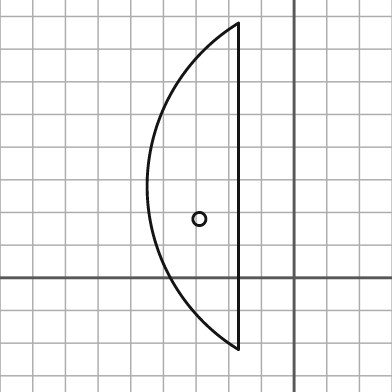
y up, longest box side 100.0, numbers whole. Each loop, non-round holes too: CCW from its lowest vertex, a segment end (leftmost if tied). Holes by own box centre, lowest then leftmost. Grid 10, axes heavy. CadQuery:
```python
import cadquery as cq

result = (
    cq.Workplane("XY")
    .moveTo(-17.0, -22.0)
    .lineTo(-17.0, 78.0)
    .threePointArc((-45.0, 28.0), (-17.0, -22.0))
    .close()
    .moveTo(-29.0, 18.0)
    .circle(2.0)
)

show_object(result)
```